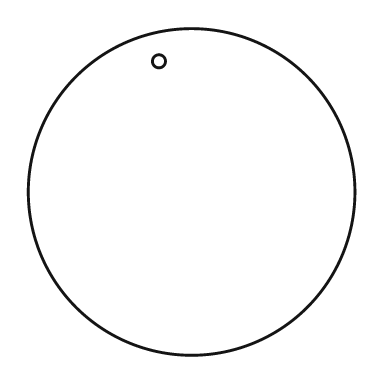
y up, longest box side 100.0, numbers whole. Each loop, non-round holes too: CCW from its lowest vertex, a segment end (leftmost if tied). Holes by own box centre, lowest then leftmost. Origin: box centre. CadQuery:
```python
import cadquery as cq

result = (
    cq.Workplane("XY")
    .moveTo(0.0, 0.0)
    .circle(50.0)
    .moveTo(-10.0, 40.0)
    .circle(2.0)
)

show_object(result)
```